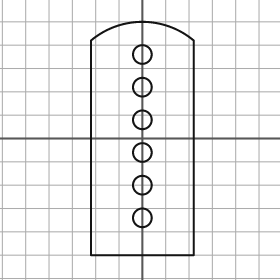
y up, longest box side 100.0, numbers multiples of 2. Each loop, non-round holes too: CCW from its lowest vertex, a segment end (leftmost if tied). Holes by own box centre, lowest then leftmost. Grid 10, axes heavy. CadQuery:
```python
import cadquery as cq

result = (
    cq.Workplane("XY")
    .moveTo(-22.0, -50.0)
    .lineTo(22.0, -50.0)
    .lineTo(22.0, 42.0)
    .threePointArc((0.0, 50.0), (-22.0, 42.0))
    .close()
    .moveTo(0.0, -34.0)
    .circle(4.0)
    .moveTo(0.0, -20.0)
    .circle(4.0)
    .moveTo(0.0, -6.0)
    .circle(4.0)
    .moveTo(0.0, 8.0)
    .circle(4.0)
    .moveTo(0.0, 22.0)
    .circle(4.0)
    .moveTo(0.0, 36.0)
    .circle(4.0)
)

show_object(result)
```